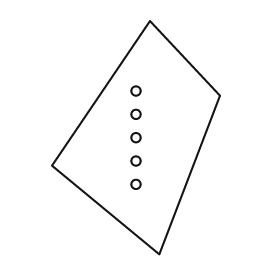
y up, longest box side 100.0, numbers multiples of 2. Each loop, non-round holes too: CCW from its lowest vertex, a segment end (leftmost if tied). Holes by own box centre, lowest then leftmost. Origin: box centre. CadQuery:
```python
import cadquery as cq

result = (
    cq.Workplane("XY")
    .moveTo(10.0, -50.0)
    .lineTo(36.0, 18.0)
    .lineTo(6.0, 50.0)
    .lineTo(-36.0, -12.0)
    .close()
    .moveTo(0.0, -20.0)
    .circle(2.0)
    .moveTo(0.0, -10.0)
    .circle(2.0)
    .moveTo(0.0, 0.0)
    .circle(2.0)
    .moveTo(0.0, 10.0)
    .circle(2.0)
    .moveTo(0.0, 20.0)
    .circle(2.0)
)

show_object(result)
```